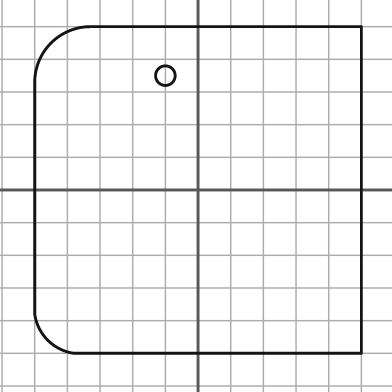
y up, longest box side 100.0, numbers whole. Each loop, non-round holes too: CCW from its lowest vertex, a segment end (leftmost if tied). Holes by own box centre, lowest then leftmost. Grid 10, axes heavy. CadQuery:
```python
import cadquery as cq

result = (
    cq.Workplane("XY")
    .moveTo(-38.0, -50.0)
    .lineTo(50.0, -50.0)
    .lineTo(50.0, 50.0)
    .lineTo(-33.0, 50.0)
    .threePointArc((-45.0, 45.0), (-50.0, 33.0))
    .lineTo(-50.0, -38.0)
    .threePointArc((-46.0, -46.0), (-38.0, -50.0))
    .close()
    .moveTo(-10.0, 35.0)
    .circle(3.0)
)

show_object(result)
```